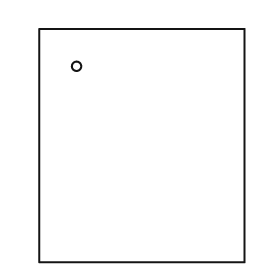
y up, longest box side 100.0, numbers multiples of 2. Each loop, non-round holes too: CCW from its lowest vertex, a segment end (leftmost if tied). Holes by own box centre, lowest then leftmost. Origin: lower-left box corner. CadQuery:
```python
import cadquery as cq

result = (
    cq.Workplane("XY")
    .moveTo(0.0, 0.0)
    .lineTo(88.0, 0.0)
    .lineTo(88.0, 100.0)
    .lineTo(0.0, 100.0)
    .close()
    .moveTo(16.0, 84.0)
    .circle(2.0)
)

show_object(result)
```